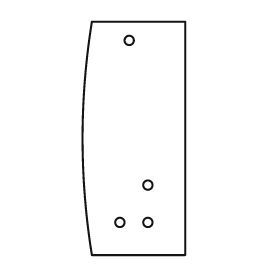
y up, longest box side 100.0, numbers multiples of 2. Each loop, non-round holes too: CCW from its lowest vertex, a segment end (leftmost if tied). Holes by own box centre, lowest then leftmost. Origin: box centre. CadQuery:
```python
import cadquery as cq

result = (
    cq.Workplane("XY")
    .moveTo(-18.0, -50.0)
    .lineTo(22.0, -50.0)
    .lineTo(22.0, 50.0)
    .lineTo(-18.0, 50.0)
    .threePointArc((-22.0, 0.0), (-18.0, -50.0))
    .close()
    .moveTo(-6.0, -36.0)
    .circle(2.0)
    .moveTo(6.0, -36.0)
    .circle(2.0)
    .moveTo(6.0, -20.0)
    .circle(2.0)
    .moveTo(-2.0, 42.0)
    .circle(2.0)
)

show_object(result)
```